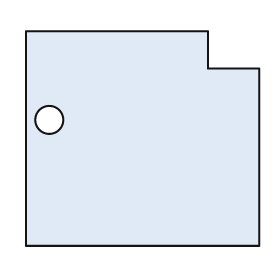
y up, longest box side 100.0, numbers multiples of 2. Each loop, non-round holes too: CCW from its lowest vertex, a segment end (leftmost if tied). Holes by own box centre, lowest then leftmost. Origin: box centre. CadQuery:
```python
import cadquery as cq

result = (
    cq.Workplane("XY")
    .moveTo(-50.0, -46.0)
    .lineTo(50.0, -46.0)
    .lineTo(50.0, 30.0)
    .lineTo(28.0, 30.0)
    .lineTo(28.0, 46.0)
    .lineTo(-50.0, 46.0)
    .close()
    .moveTo(-40.0, 8.0)
    .circle(6.0)
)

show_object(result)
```